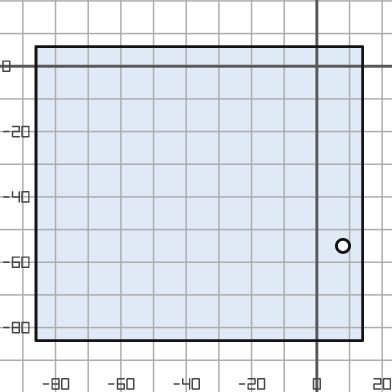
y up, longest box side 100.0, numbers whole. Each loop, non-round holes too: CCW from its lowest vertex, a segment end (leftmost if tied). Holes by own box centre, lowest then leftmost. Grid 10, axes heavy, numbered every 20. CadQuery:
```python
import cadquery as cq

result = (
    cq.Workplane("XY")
    .moveTo(-86.0, -84.0)
    .lineTo(14.0, -84.0)
    .lineTo(14.0, 6.0)
    .lineTo(-86.0, 6.0)
    .close()
    .moveTo(8.0, -55.0)
    .circle(2.0)
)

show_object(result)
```